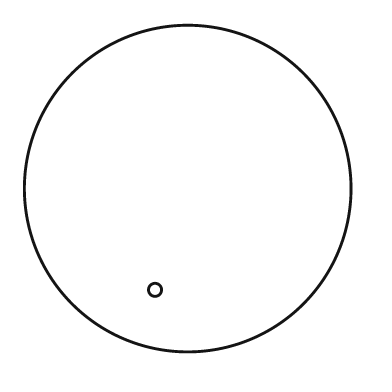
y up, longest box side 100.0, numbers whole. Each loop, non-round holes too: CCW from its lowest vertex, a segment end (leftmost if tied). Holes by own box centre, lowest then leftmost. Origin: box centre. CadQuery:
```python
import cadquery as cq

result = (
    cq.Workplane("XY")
    .moveTo(0.0, 0.0)
    .circle(50.0)
    .moveTo(-10.0, -31.0)
    .circle(2.0)
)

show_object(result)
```